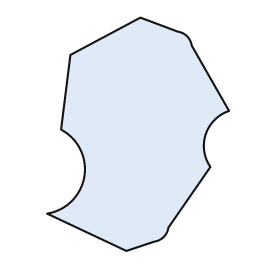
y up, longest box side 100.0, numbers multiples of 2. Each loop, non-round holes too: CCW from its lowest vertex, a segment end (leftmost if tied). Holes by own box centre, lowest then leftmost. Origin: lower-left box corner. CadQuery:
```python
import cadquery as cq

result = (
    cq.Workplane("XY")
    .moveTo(34.0, 0.0)
    .lineTo(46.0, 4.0)
    .threePointArc((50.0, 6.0), (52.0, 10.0))
    .lineTo(70.0, 36.0)
    .threePointArc((68.0, 50.0), (78.0, 60.0))
    .lineTo(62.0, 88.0)
    .threePointArc((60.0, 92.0), (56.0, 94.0))
    .lineTo(40.0, 100.0)
    .lineTo(10.0, 84.0)
    .lineTo(6.0, 52.0)
    .threePointArc((16.0, 32.0), (0.0, 16.0))
    .close()
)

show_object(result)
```